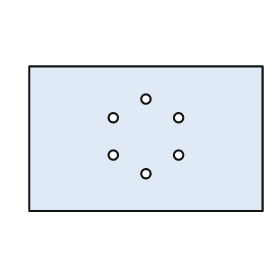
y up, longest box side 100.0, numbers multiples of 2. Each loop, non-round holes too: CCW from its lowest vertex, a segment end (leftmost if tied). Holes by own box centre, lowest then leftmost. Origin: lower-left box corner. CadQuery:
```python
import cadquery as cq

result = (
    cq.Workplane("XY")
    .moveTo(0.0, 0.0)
    .lineTo(100.0, 0.0)
    .lineTo(100.0, 62.0)
    .lineTo(0.0, 62.0)
    .close()
    .moveTo(50.0, 16.0)
    .circle(2.0)
    .moveTo(36.0, 24.0)
    .circle(2.0)
    .moveTo(64.0, 24.0)
    .circle(2.0)
    .moveTo(36.0, 40.0)
    .circle(2.0)
    .moveTo(64.0, 40.0)
    .circle(2.0)
    .moveTo(50.0, 48.0)
    .circle(2.0)
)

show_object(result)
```